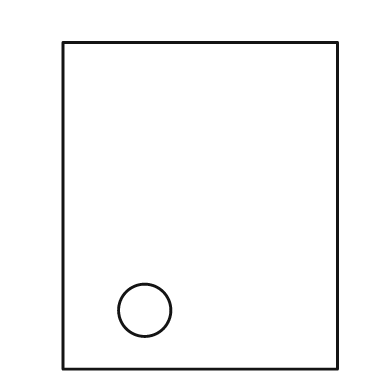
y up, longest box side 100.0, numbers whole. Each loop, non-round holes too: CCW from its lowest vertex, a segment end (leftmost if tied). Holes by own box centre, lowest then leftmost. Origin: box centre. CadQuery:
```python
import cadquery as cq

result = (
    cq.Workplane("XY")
    .moveTo(-42.0, -50.0)
    .lineTo(42.0, -50.0)
    .lineTo(42.0, 50.0)
    .lineTo(-42.0, 50.0)
    .close()
    .moveTo(-17.0, -32.0)
    .circle(8.0)
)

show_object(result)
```